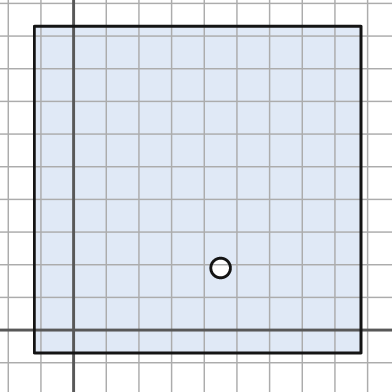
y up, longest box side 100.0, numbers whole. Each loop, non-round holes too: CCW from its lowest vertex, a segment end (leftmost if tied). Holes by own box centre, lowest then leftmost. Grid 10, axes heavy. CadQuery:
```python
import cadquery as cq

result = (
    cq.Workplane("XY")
    .moveTo(-12.0, -7.0)
    .lineTo(88.0, -7.0)
    .lineTo(88.0, 93.0)
    .lineTo(-12.0, 93.0)
    .close()
    .moveTo(45.0, 19.0)
    .circle(3.0)
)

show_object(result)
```